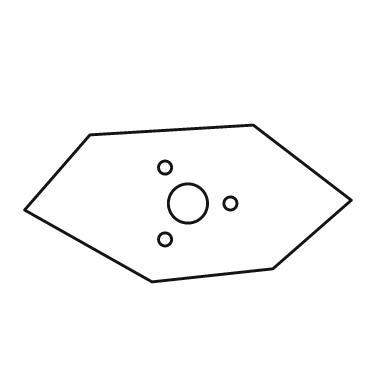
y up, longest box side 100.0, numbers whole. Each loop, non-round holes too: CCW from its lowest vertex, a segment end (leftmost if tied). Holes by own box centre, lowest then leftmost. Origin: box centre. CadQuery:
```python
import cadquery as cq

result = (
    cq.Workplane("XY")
    .moveTo(-11.0, -24.0)
    .lineTo(26.0, -20.0)
    .lineTo(50.0, 1.0)
    .lineTo(20.0, 24.0)
    .lineTo(-30.0, 21.0)
    .lineTo(-50.0, -2.0)
    .close()
    .moveTo(-7.0, -11.0)
    .circle(2.0)
    .moveTo(0.0, 0.0)
    .circle(6.0)
    .moveTo(13.0, 0.0)
    .circle(2.0)
    .moveTo(-7.0, 11.0)
    .circle(2.0)
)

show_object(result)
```